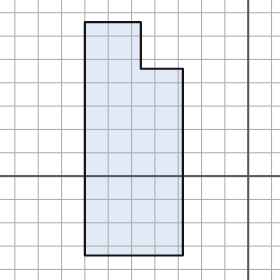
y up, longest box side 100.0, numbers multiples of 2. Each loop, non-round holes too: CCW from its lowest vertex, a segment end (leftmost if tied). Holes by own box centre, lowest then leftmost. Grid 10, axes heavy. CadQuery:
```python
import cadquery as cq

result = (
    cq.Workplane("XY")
    .moveTo(-70.0, -34.0)
    .lineTo(-28.0, -34.0)
    .lineTo(-28.0, 46.0)
    .lineTo(-46.0, 46.0)
    .lineTo(-46.0, 66.0)
    .lineTo(-70.0, 66.0)
    .close()
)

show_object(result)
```